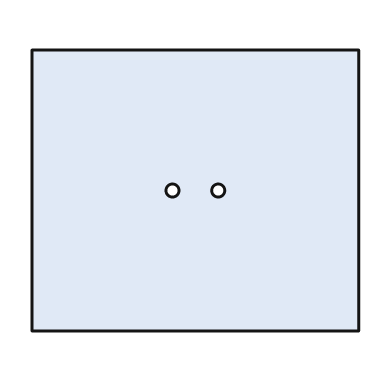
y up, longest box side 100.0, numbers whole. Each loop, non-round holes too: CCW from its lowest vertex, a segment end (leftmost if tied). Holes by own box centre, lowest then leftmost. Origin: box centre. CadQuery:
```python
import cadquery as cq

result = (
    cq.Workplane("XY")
    .moveTo(-50.0, -43.0)
    .lineTo(50.0, -43.0)
    .lineTo(50.0, 43.0)
    .lineTo(-50.0, 43.0)
    .close()
    .moveTo(-7.0, 0.0)
    .circle(2.0)
    .moveTo(7.0, 0.0)
    .circle(2.0)
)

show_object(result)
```